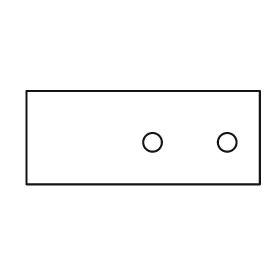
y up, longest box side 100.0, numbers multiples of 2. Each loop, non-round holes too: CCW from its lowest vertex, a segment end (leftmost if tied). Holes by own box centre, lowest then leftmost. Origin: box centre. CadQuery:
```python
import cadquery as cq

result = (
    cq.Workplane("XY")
    .moveTo(-50.0, -20.0)
    .lineTo(50.0, -20.0)
    .lineTo(50.0, 20.0)
    .lineTo(-50.0, 20.0)
    .close()
    .moveTo(4.0, -2.0)
    .circle(4.0)
    .moveTo(36.0, -2.0)
    .circle(4.0)
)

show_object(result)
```